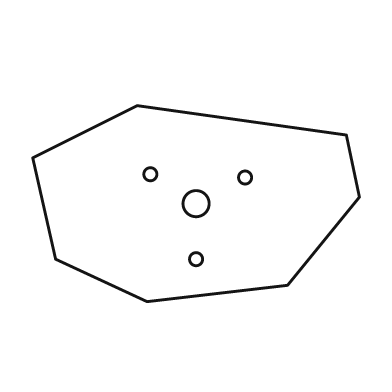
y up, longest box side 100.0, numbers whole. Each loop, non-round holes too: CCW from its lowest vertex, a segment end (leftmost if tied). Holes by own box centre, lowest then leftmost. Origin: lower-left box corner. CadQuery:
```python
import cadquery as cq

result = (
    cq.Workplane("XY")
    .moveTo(35.0, 0.0)
    .lineTo(78.0, 5.0)
    .lineTo(100.0, 32.0)
    .lineTo(96.0, 51.0)
    .lineTo(32.0, 60.0)
    .lineTo(0.0, 44.0)
    .lineTo(7.0, 13.0)
    .close()
    .moveTo(50.0, 13.0)
    .circle(2.0)
    .moveTo(50.0, 30.0)
    .circle(4.0)
    .moveTo(65.0, 38.0)
    .circle(2.0)
    .moveTo(36.0, 39.0)
    .circle(2.0)
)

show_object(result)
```